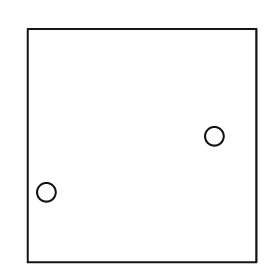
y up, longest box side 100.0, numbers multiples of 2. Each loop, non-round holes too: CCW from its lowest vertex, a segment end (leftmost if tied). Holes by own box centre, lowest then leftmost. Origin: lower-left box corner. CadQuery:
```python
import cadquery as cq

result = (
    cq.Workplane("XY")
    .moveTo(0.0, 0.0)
    .lineTo(98.0, 0.0)
    .lineTo(98.0, 100.0)
    .lineTo(0.0, 100.0)
    .close()
    .moveTo(8.0, 30.0)
    .circle(4.0)
    .moveTo(80.0, 54.0)
    .circle(4.0)
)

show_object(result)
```